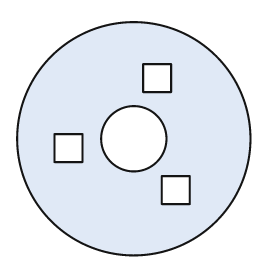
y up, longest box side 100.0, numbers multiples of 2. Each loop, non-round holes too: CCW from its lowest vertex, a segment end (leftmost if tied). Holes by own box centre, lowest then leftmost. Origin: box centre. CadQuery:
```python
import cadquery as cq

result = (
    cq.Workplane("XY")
    .moveTo(0.0, 0.0)
    .circle(50.0)
    .moveTo(12.0, -28.0)
    .lineTo(24.0, -28.0)
    .lineTo(24.0, -16.0)
    .lineTo(12.0, -16.0)
    .close()
    .moveTo(-34.0, -10.0)
    .lineTo(-22.0, -10.0)
    .lineTo(-22.0, 2.0)
    .lineTo(-34.0, 2.0)
    .close()
    .moveTo(0.0, 0.0)
    .circle(14.0)
    .moveTo(4.0, 20.0)
    .lineTo(16.0, 20.0)
    .lineTo(16.0, 32.0)
    .lineTo(4.0, 32.0)
    .close()
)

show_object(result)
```